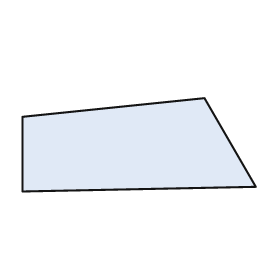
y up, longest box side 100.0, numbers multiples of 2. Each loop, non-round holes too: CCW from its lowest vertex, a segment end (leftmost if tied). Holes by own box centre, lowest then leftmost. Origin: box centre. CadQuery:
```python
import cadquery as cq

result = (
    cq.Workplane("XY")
    .moveTo(-50.0, -20.0)
    .lineTo(50.0, -18.0)
    .lineTo(28.0, 20.0)
    .lineTo(-50.0, 12.0)
    .close()
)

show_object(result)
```